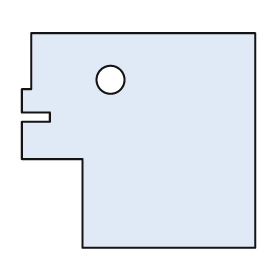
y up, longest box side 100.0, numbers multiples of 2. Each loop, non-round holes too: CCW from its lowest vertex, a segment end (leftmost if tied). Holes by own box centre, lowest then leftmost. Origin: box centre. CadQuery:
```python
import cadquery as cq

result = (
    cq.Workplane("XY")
    .moveTo(-24.0, -46.0)
    .lineTo(50.0, -46.0)
    .lineTo(50.0, 46.0)
    .lineTo(-46.0, 46.0)
    .lineTo(-46.0, 22.0)
    .lineTo(-50.0, 22.0)
    .lineTo(-50.0, 12.0)
    .lineTo(-38.0, 12.0)
    .lineTo(-38.0, 8.0)
    .lineTo(-50.0, 8.0)
    .lineTo(-50.0, -8.0)
    .lineTo(-24.0, -8.0)
    .close()
    .moveTo(-12.0, 26.0)
    .circle(6.0)
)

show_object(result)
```